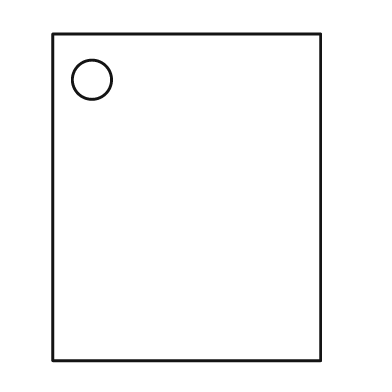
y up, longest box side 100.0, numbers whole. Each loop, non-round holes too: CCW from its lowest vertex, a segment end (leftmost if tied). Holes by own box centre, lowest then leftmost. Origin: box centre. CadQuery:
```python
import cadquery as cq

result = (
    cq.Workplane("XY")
    .moveTo(-41.0, -50.0)
    .lineTo(41.0, -50.0)
    .lineTo(41.0, 50.0)
    .lineTo(-41.0, 50.0)
    .close()
    .moveTo(-29.0, 36.0)
    .circle(6.0)
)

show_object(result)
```